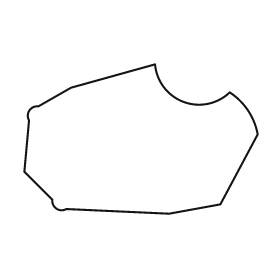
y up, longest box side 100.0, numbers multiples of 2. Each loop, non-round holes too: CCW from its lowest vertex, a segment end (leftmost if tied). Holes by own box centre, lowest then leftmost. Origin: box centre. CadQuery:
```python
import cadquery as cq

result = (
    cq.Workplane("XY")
    .moveTo(12.0, -32.0)
    .lineTo(34.0, -28.0)
    .lineTo(50.0, 2.0)
    .threePointArc((46.0, 12.0), (38.0, 20.0))
    .threePointArc((18.0, 16.0), (6.0, 32.0))
    .lineTo(-30.0, 22.0)
    .lineTo(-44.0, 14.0)
    .threePointArc((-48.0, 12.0), (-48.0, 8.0))
    .lineTo(-50.0, -14.0)
    .lineTo(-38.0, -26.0)
    .threePointArc((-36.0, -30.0), (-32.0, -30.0))
    .close()
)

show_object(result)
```